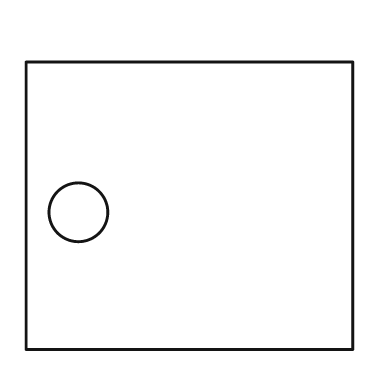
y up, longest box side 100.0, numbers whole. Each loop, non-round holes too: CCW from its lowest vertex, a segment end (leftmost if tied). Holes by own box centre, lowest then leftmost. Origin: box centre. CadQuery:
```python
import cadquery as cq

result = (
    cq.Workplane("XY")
    .moveTo(-50.0, -44.0)
    .lineTo(50.0, -44.0)
    .lineTo(50.0, 44.0)
    .lineTo(-50.0, 44.0)
    .close()
    .moveTo(-34.0, -2.0)
    .circle(9.0)
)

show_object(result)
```